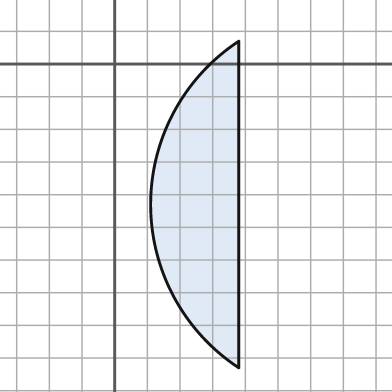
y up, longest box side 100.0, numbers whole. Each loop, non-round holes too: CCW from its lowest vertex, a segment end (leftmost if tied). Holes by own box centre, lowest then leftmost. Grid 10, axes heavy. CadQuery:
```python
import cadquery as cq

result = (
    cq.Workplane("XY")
    .moveTo(38.0, -93.0)
    .lineTo(38.0, 7.0)
    .threePointArc((11.0, -43.0), (38.0, -93.0))
    .close()
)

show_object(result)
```